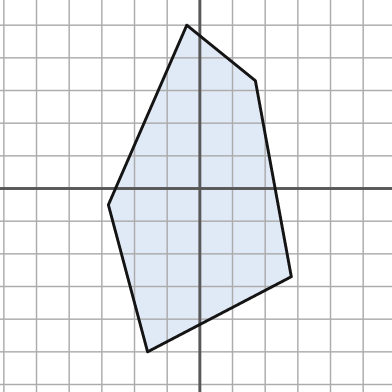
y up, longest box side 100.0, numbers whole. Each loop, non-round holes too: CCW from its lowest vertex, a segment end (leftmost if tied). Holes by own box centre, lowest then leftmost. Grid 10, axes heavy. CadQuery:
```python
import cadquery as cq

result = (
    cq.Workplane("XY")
    .moveTo(-16.0, -50.0)
    .lineTo(28.0, -27.0)
    .lineTo(17.0, 33.0)
    .lineTo(-4.0, 50.0)
    .lineTo(-28.0, -5.0)
    .close()
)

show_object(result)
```